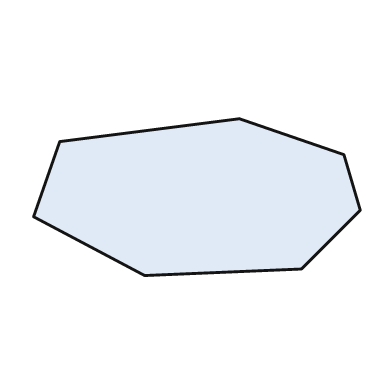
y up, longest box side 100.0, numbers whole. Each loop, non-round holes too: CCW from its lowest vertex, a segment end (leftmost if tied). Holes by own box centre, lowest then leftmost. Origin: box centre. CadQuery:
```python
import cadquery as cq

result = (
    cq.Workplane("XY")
    .moveTo(-16.0, -24.0)
    .lineTo(32.0, -22.0)
    .lineTo(50.0, -4.0)
    .lineTo(45.0, 13.0)
    .lineTo(13.0, 24.0)
    .lineTo(-42.0, 17.0)
    .lineTo(-50.0, -6.0)
    .close()
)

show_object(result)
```